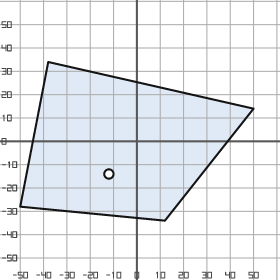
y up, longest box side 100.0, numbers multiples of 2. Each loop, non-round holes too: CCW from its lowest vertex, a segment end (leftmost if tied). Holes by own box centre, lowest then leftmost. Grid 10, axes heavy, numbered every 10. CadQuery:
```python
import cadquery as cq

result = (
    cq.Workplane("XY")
    .moveTo(12.0, -34.0)
    .lineTo(50.0, 14.0)
    .lineTo(-38.0, 34.0)
    .lineTo(-50.0, -28.0)
    .close()
    .moveTo(-12.0, -14.0)
    .circle(2.0)
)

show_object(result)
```